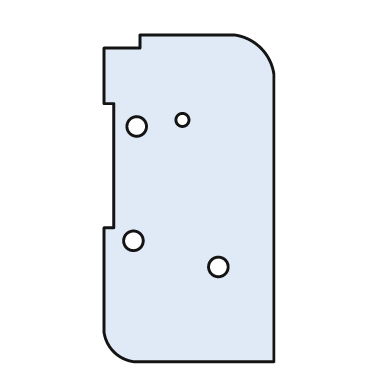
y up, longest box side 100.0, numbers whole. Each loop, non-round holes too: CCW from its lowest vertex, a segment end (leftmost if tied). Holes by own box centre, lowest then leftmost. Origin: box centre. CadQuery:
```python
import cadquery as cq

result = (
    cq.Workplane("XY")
    .moveTo(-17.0, -50.0)
    .lineTo(26.0, -50.0)
    .lineTo(26.0, 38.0)
    .threePointArc((22.0, 46.0), (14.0, 50.0))
    .lineTo(-15.0, 50.0)
    .lineTo(-15.0, 46.0)
    .lineTo(-26.0, 46.0)
    .lineTo(-26.0, 29.0)
    .lineTo(-23.0, 29.0)
    .lineTo(-23.0, -9.0)
    .lineTo(-26.0, -9.0)
    .lineTo(-26.0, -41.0)
    .threePointArc((-23.0, -47.0), (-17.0, -50.0))
    .close()
    .moveTo(9.0, -21.0)
    .circle(3.0)
    .moveTo(-17.0, -13.0)
    .circle(3.0)
    .moveTo(-16.0, 22.0)
    .circle(3.0)
    .moveTo(-2.0, 24.0)
    .circle(2.0)
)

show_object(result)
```